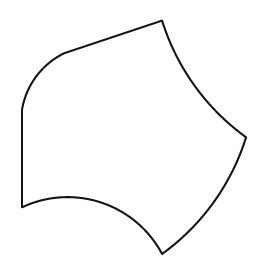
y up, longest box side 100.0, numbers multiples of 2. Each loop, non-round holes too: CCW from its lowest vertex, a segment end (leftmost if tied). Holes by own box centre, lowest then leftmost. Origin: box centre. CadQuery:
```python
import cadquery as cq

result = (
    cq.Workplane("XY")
    .moveTo(12.0, -50.0)
    .threePointArc((34.0, -28.0), (48.0, 0.0))
    .threePointArc((26.0, 22.0), (12.0, 50.0))
    .lineTo(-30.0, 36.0)
    .threePointArc((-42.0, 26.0), (-48.0, 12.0))
    .lineTo(-48.0, -30.0)
    .threePointArc((-14.0, -28.0), (12.0, -50.0))
    .close()
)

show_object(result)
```